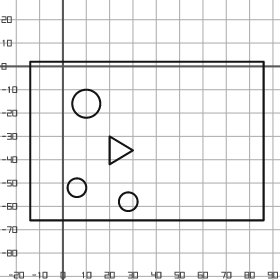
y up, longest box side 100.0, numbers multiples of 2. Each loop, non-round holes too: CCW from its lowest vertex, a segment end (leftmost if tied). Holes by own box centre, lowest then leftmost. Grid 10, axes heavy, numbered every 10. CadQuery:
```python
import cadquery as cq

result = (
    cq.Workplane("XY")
    .moveTo(-14.0, -66.0)
    .lineTo(86.0, -66.0)
    .lineTo(86.0, 2.0)
    .lineTo(-14.0, 2.0)
    .close()
    .moveTo(28.0, -58.0)
    .circle(4.0)
    .moveTo(6.0, -52.0)
    .circle(4.0)
    .moveTo(20.0, -42.0)
    .lineTo(30.0, -36.0)
    .lineTo(20.0, -30.0)
    .close()
    .moveTo(10.0, -16.0)
    .circle(6.0)
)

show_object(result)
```